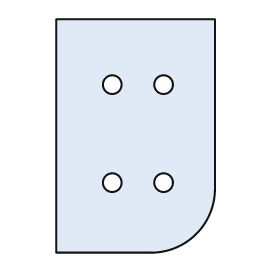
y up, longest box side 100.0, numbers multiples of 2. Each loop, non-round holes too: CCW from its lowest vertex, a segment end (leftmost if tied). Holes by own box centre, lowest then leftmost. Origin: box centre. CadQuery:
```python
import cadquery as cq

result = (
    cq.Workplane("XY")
    .moveTo(-34.0, -50.0)
    .lineTo(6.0, -50.0)
    .threePointArc((26.0, -42.0), (34.0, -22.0))
    .lineTo(34.0, 50.0)
    .lineTo(-34.0, 50.0)
    .close()
    .moveTo(-10.0, -20.0)
    .circle(4.0)
    .moveTo(12.0, -20.0)
    .circle(4.0)
    .moveTo(-10.0, 22.0)
    .circle(4.0)
    .moveTo(12.0, 22.0)
    .circle(4.0)
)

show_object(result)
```